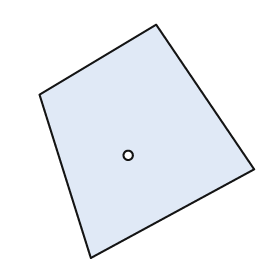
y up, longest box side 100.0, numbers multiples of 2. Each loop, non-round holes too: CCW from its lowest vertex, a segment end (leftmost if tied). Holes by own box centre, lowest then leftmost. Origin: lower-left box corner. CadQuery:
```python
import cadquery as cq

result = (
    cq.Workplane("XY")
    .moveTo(22.0, 0.0)
    .lineTo(92.0, 38.0)
    .lineTo(50.0, 100.0)
    .lineTo(0.0, 70.0)
    .close()
    .moveTo(38.0, 44.0)
    .circle(2.0)
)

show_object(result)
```